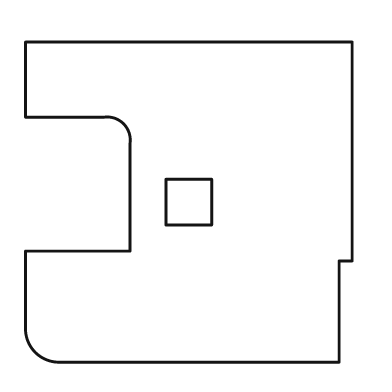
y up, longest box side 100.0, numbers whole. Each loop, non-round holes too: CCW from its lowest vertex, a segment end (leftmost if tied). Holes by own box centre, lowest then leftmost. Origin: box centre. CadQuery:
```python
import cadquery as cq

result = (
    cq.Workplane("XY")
    .moveTo(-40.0, -49.0)
    .lineTo(46.0, -49.0)
    .lineTo(46.0, -18.0)
    .lineTo(50.0, -18.0)
    .lineTo(50.0, 49.0)
    .lineTo(-50.0, 49.0)
    .lineTo(-50.0, 26.0)
    .lineTo(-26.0, 26.0)
    .threePointArc((-20.0, 24.0), (-18.0, 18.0))
    .lineTo(-18.0, -15.0)
    .lineTo(-50.0, -15.0)
    .lineTo(-50.0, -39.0)
    .threePointArc((-47.0, -46.0), (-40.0, -49.0))
    .close()
    .moveTo(-7.0, -7.0)
    .lineTo(7.0, -7.0)
    .lineTo(7.0, 7.0)
    .lineTo(-7.0, 7.0)
    .close()
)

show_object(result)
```